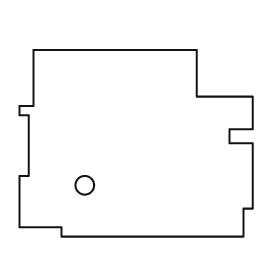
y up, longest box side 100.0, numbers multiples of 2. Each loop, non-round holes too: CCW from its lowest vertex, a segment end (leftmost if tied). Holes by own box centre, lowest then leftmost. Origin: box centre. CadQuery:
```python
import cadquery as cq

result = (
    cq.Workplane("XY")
    .moveTo(-32.0, -40.0)
    .lineTo(46.0, -40.0)
    .lineTo(46.0, -28.0)
    .lineTo(50.0, -28.0)
    .lineTo(50.0, 0.0)
    .lineTo(40.0, 0.0)
    .lineTo(40.0, 6.0)
    .lineTo(50.0, 6.0)
    .lineTo(50.0, 20.0)
    .lineTo(26.0, 20.0)
    .lineTo(26.0, 40.0)
    .lineTo(-44.0, 40.0)
    .lineTo(-44.0, 16.0)
    .lineTo(-50.0, 16.0)
    .lineTo(-50.0, 12.0)
    .lineTo(-46.0, 12.0)
    .lineTo(-46.0, -14.0)
    .lineTo(-50.0, -14.0)
    .lineTo(-50.0, -36.0)
    .lineTo(-32.0, -36.0)
    .close()
    .moveTo(-22.0, -18.0)
    .circle(4.0)
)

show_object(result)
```